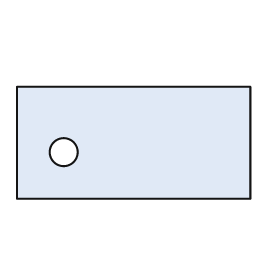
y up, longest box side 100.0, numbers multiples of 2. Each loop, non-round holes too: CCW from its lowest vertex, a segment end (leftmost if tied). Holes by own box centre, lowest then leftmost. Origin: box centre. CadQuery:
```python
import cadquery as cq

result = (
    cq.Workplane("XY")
    .moveTo(-50.0, -24.0)
    .lineTo(50.0, -24.0)
    .lineTo(50.0, 24.0)
    .lineTo(-50.0, 24.0)
    .close()
    .moveTo(-30.0, -4.0)
    .circle(6.0)
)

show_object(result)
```